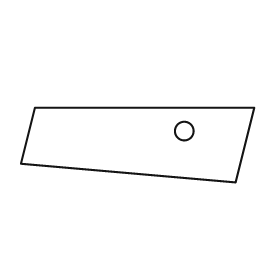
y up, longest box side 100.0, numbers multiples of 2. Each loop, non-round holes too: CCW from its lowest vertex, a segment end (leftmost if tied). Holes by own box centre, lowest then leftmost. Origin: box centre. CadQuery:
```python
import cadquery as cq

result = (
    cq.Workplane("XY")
    .moveTo(42.0, -16.0)
    .lineTo(50.0, 16.0)
    .lineTo(-44.0, 16.0)
    .lineTo(-50.0, -8.0)
    .close()
    .moveTo(20.0, 6.0)
    .circle(4.0)
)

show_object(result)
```